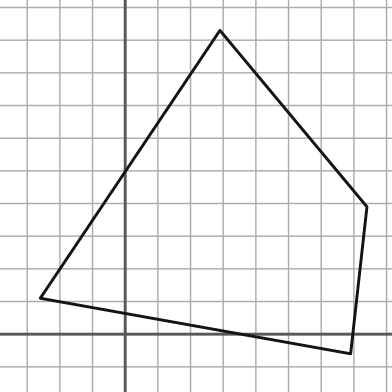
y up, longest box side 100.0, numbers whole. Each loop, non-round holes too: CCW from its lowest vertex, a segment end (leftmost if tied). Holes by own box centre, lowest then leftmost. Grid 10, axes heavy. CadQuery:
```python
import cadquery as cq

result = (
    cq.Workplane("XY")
    .moveTo(69.0, -6.0)
    .lineTo(74.0, 39.0)
    .lineTo(29.0, 93.0)
    .lineTo(-26.0, 11.0)
    .close()
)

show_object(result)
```